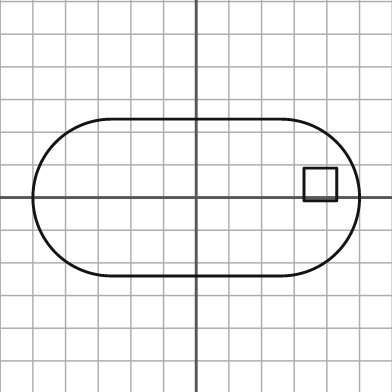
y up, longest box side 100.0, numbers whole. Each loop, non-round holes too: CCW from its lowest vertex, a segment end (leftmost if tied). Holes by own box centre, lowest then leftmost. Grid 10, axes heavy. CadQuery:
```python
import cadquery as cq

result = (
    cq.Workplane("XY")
    .moveTo(-26.0, -24.0)
    .lineTo(26.0, -24.0)
    .threePointArc((50.0, 0.0), (26.0, 24.0))
    .lineTo(-26.0, 24.0)
    .threePointArc((-50.0, 0.0), (-26.0, -24.0))
    .close()
    .moveTo(33.0, -1.0)
    .lineTo(43.0, -1.0)
    .lineTo(43.0, 9.0)
    .lineTo(33.0, 9.0)
    .close()
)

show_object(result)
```